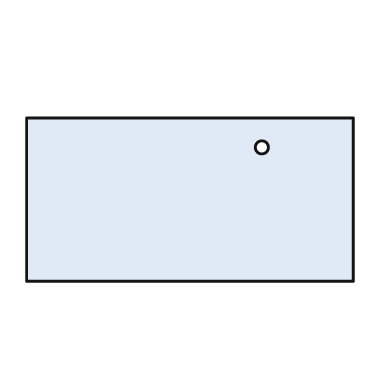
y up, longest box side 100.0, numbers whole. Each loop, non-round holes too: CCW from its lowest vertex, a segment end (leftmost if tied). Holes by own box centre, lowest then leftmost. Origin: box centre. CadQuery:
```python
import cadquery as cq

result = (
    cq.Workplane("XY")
    .moveTo(-50.0, -25.0)
    .lineTo(50.0, -25.0)
    .lineTo(50.0, 25.0)
    .lineTo(-50.0, 25.0)
    .close()
    .moveTo(22.0, 16.0)
    .circle(2.0)
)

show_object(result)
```